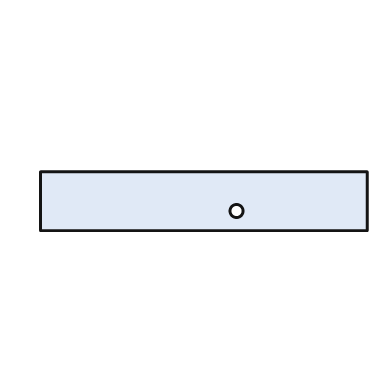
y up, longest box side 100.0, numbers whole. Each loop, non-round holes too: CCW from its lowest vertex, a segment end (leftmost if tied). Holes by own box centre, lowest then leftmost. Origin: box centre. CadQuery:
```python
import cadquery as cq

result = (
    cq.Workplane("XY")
    .moveTo(-50.0, -9.0)
    .lineTo(50.0, -9.0)
    .lineTo(50.0, 9.0)
    .lineTo(-50.0, 9.0)
    .close()
    .moveTo(10.0, -3.0)
    .circle(2.0)
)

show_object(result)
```